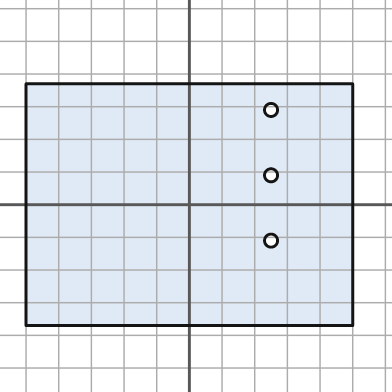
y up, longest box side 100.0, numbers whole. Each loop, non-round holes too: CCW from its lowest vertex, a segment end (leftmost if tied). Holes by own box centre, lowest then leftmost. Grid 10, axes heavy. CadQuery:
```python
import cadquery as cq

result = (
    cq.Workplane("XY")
    .moveTo(-50.0, -37.0)
    .lineTo(50.0, -37.0)
    .lineTo(50.0, 37.0)
    .lineTo(-50.0, 37.0)
    .close()
    .moveTo(25.0, -11.0)
    .circle(2.0)
    .moveTo(25.0, 9.0)
    .circle(2.0)
    .moveTo(25.0, 29.0)
    .circle(2.0)
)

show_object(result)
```